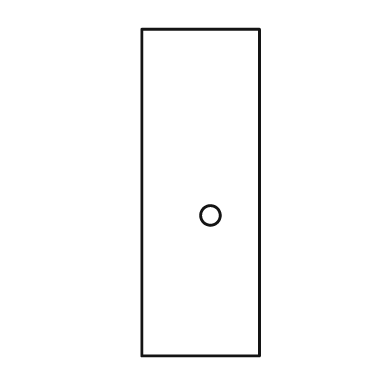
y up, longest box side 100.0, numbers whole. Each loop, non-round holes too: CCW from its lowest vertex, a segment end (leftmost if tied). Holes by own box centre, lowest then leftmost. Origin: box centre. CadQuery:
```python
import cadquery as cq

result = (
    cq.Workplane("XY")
    .moveTo(-18.0, -50.0)
    .lineTo(18.0, -50.0)
    .lineTo(18.0, 50.0)
    .lineTo(-18.0, 50.0)
    .close()
    .moveTo(3.0, -7.0)
    .circle(3.0)
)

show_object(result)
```